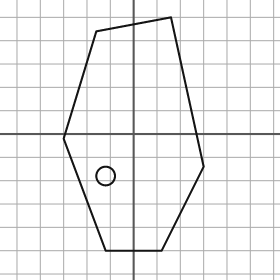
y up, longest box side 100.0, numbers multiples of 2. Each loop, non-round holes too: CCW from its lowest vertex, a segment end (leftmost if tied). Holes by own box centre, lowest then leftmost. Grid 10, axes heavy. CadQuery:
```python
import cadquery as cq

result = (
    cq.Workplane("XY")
    .moveTo(-12.0, -50.0)
    .lineTo(12.0, -50.0)
    .lineTo(30.0, -14.0)
    .lineTo(16.0, 50.0)
    .lineTo(-16.0, 44.0)
    .lineTo(-30.0, -2.0)
    .close()
    .moveTo(-12.0, -18.0)
    .circle(4.0)
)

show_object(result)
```